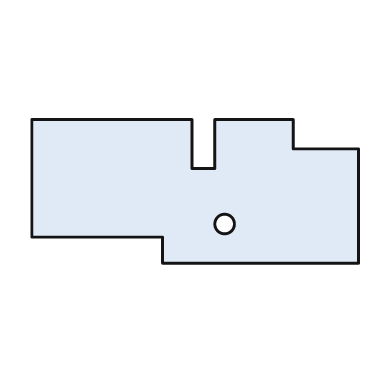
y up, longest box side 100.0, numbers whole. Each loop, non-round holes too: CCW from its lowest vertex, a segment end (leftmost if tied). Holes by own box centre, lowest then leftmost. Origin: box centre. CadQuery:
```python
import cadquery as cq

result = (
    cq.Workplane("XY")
    .moveTo(-10.0, -22.0)
    .lineTo(50.0, -22.0)
    .lineTo(50.0, 13.0)
    .lineTo(30.0, 13.0)
    .lineTo(30.0, 22.0)
    .lineTo(6.0, 22.0)
    .lineTo(6.0, 7.0)
    .lineTo(-1.0, 7.0)
    .lineTo(-1.0, 22.0)
    .lineTo(-50.0, 22.0)
    .lineTo(-50.0, -14.0)
    .lineTo(-10.0, -14.0)
    .close()
    .moveTo(9.0, -10.0)
    .circle(3.0)
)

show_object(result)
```